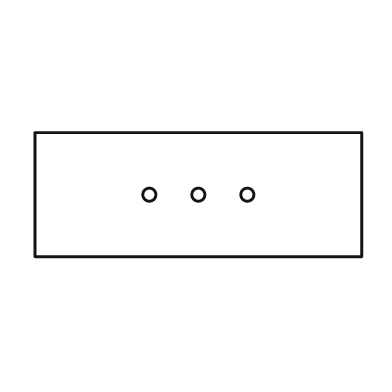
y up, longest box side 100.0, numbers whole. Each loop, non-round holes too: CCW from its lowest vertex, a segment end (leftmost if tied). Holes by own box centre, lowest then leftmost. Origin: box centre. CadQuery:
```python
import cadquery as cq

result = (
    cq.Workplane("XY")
    .moveTo(-50.0, -19.0)
    .lineTo(50.0, -19.0)
    .lineTo(50.0, 19.0)
    .lineTo(-50.0, 19.0)
    .close()
    .moveTo(-15.0, 0.0)
    .circle(2.0)
    .moveTo(0.0, 0.0)
    .circle(2.0)
    .moveTo(15.0, 0.0)
    .circle(2.0)
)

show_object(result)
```